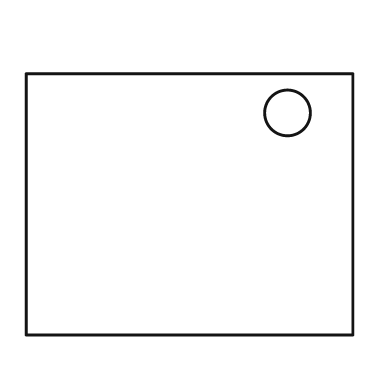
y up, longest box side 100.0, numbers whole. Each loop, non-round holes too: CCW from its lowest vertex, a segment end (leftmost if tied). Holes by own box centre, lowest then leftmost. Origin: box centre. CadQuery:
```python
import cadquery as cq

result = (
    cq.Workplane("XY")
    .moveTo(-50.0, -40.0)
    .lineTo(50.0, -40.0)
    .lineTo(50.0, 40.0)
    .lineTo(-50.0, 40.0)
    .close()
    .moveTo(30.0, 28.0)
    .circle(7.0)
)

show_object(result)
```